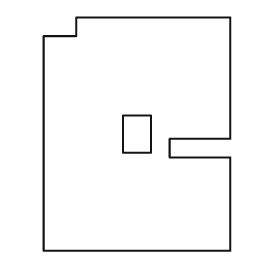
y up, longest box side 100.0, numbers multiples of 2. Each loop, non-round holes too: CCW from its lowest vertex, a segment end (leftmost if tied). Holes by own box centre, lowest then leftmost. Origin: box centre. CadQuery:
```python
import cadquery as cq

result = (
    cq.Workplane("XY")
    .moveTo(-40.0, -50.0)
    .lineTo(40.0, -50.0)
    .lineTo(40.0, -10.0)
    .lineTo(14.0, -10.0)
    .lineTo(14.0, -2.0)
    .lineTo(40.0, -2.0)
    .lineTo(40.0, 50.0)
    .lineTo(-26.0, 50.0)
    .lineTo(-26.0, 42.0)
    .lineTo(-40.0, 42.0)
    .close()
    .moveTo(-6.0, -8.0)
    .lineTo(6.0, -8.0)
    .lineTo(6.0, 8.0)
    .lineTo(-6.0, 8.0)
    .close()
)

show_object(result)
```